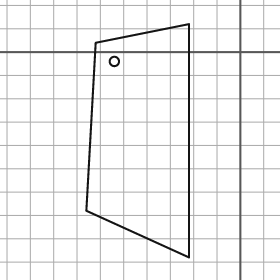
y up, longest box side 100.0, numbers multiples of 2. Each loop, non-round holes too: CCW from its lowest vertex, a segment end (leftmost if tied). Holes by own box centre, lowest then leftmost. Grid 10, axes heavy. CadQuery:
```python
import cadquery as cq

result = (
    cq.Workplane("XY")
    .moveTo(-22.0, -88.0)
    .lineTo(-22.0, 12.0)
    .lineTo(-62.0, 4.0)
    .lineTo(-66.0, -68.0)
    .close()
    .moveTo(-54.0, -4.0)
    .circle(2.0)
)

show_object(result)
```